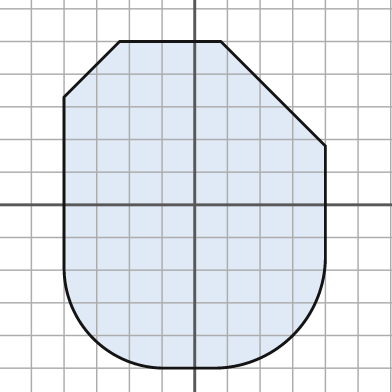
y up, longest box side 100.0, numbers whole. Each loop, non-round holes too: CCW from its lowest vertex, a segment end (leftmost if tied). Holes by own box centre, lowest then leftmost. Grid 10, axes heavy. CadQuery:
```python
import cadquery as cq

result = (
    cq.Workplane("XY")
    .moveTo(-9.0, -50.0)
    .lineTo(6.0, -50.0)
    .threePointArc((30.0, -40.0), (40.0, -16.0))
    .lineTo(40.0, 18.0)
    .lineTo(8.0, 50.0)
    .lineTo(-23.0, 50.0)
    .lineTo(-40.0, 33.0)
    .lineTo(-40.0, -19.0)
    .threePointArc((-31.0, -41.0), (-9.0, -50.0))
    .close()
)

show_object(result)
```